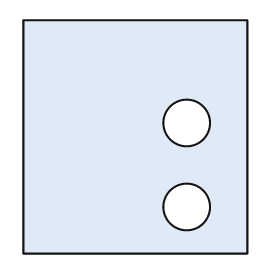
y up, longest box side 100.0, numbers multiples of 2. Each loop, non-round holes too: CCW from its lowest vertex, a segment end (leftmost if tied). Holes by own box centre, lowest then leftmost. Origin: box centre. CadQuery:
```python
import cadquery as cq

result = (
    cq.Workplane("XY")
    .moveTo(-48.0, -50.0)
    .lineTo(48.0, -50.0)
    .lineTo(48.0, 50.0)
    .lineTo(-48.0, 50.0)
    .close()
    .moveTo(22.0, -30.0)
    .circle(10.0)
    .moveTo(22.0, 6.0)
    .circle(10.0)
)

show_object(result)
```